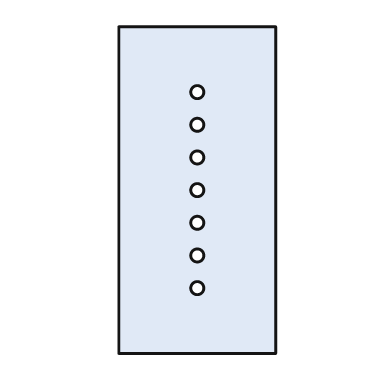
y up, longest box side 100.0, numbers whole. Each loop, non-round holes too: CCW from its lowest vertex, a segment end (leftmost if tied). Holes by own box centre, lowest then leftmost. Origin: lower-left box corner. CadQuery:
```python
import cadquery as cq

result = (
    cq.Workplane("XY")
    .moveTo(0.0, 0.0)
    .lineTo(48.0, 0.0)
    .lineTo(48.0, 100.0)
    .lineTo(0.0, 100.0)
    .close()
    .moveTo(24.0, 20.0)
    .circle(2.0)
    .moveTo(24.0, 30.0)
    .circle(2.0)
    .moveTo(24.0, 40.0)
    .circle(2.0)
    .moveTo(24.0, 50.0)
    .circle(2.0)
    .moveTo(24.0, 60.0)
    .circle(2.0)
    .moveTo(24.0, 70.0)
    .circle(2.0)
    .moveTo(24.0, 80.0)
    .circle(2.0)
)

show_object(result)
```